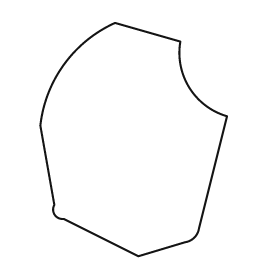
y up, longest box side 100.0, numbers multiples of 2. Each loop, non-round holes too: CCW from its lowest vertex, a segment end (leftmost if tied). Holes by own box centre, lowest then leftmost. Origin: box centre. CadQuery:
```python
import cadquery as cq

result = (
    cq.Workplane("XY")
    .moveTo(2.0, -50.0)
    .lineTo(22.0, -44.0)
    .threePointArc((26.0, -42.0), (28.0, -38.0))
    .lineTo(40.0, 10.0)
    .threePointArc((24.0, 22.0), (20.0, 42.0))
    .lineTo(-8.0, 50.0)
    .threePointArc((-30.0, 32.0), (-40.0, 6.0))
    .lineTo(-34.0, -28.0)
    .threePointArc((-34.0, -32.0), (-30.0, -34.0))
    .close()
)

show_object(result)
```